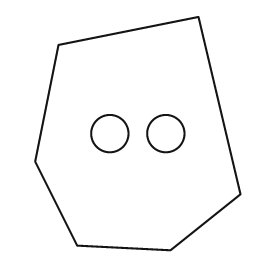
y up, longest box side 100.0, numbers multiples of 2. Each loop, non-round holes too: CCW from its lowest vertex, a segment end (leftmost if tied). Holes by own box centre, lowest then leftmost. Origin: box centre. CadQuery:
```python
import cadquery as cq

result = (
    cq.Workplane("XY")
    .moveTo(14.0, -50.0)
    .lineTo(44.0, -26.0)
    .lineTo(26.0, 50.0)
    .lineTo(-34.0, 38.0)
    .lineTo(-44.0, -12.0)
    .lineTo(-26.0, -48.0)
    .close()
    .moveTo(-12.0, 0.0)
    .circle(8.0)
    .moveTo(12.0, 0.0)
    .circle(8.0)
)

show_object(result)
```